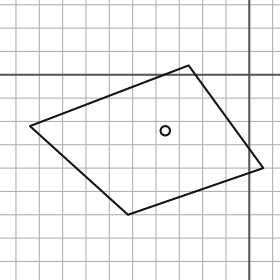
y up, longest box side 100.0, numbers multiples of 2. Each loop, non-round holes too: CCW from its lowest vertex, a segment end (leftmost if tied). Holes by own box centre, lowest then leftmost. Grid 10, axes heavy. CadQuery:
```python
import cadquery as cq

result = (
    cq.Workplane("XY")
    .moveTo(-52.0, -60.0)
    .lineTo(6.0, -40.0)
    .lineTo(-26.0, 4.0)
    .lineTo(-94.0, -22.0)
    .close()
    .moveTo(-36.0, -24.0)
    .circle(2.0)
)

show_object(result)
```